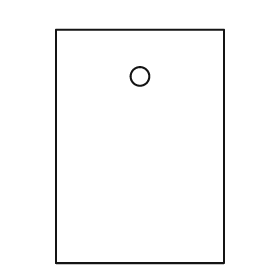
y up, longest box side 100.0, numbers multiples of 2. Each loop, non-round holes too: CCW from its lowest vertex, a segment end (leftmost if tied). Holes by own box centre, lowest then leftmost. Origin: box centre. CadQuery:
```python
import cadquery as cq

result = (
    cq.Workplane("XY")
    .moveTo(-36.0, -50.0)
    .lineTo(36.0, -50.0)
    .lineTo(36.0, 50.0)
    .lineTo(-36.0, 50.0)
    .close()
    .moveTo(0.0, 30.0)
    .circle(4.0)
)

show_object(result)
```